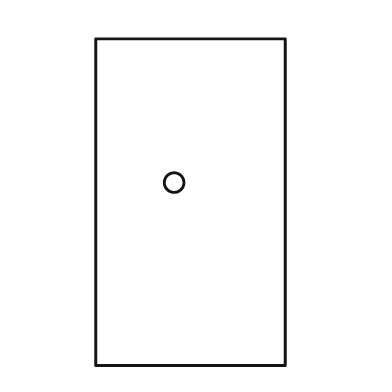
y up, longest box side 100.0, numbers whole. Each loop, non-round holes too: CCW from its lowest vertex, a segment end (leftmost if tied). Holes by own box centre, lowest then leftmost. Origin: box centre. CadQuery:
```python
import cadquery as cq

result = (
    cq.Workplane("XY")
    .moveTo(-29.0, -50.0)
    .lineTo(29.0, -50.0)
    .lineTo(29.0, 50.0)
    .lineTo(-29.0, 50.0)
    .close()
    .moveTo(-5.0, 6.0)
    .circle(3.0)
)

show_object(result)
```